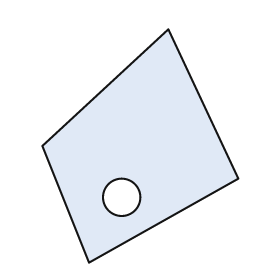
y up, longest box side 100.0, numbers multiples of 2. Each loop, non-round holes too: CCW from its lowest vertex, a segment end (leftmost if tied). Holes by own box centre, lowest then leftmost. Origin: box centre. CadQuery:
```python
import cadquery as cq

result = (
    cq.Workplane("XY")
    .moveTo(-22.0, -50.0)
    .lineTo(42.0, -14.0)
    .lineTo(12.0, 50.0)
    .lineTo(-42.0, 0.0)
    .close()
    .moveTo(-8.0, -22.0)
    .circle(8.0)
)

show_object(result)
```